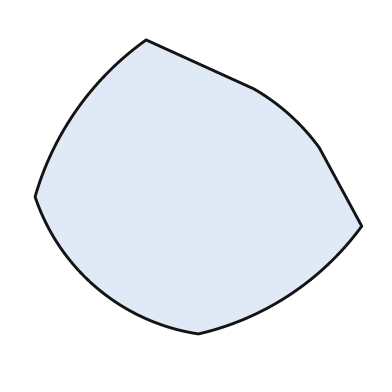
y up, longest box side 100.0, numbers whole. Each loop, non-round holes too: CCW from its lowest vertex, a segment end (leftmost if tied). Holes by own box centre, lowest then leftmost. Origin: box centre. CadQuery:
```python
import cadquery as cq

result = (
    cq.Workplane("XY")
    .moveTo(0.0, -45.0)
    .threePointArc((28.0, -33.0), (50.0, -12.0))
    .lineTo(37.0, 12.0)
    .threePointArc((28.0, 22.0), (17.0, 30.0))
    .lineTo(-16.0, 45.0)
    .threePointArc((-37.0, 24.0), (-50.0, -3.0))
    .threePointArc((-31.0, -31.0), (0.0, -45.0))
    .close()
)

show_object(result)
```